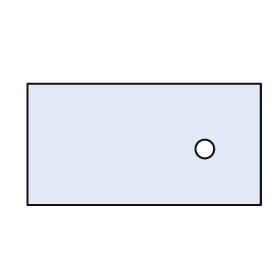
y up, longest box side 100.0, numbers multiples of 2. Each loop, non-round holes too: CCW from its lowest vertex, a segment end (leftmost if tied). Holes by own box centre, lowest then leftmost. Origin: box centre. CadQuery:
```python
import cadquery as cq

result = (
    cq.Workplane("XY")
    .moveTo(-50.0, -26.0)
    .lineTo(50.0, -26.0)
    .lineTo(50.0, 26.0)
    .lineTo(-50.0, 26.0)
    .close()
    .moveTo(26.0, -2.0)
    .circle(4.0)
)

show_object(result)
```